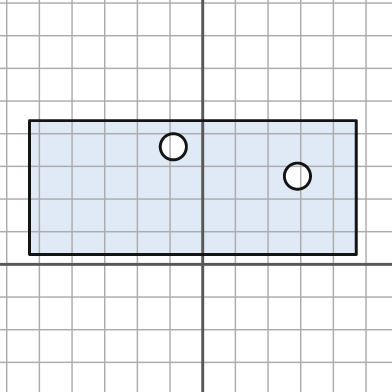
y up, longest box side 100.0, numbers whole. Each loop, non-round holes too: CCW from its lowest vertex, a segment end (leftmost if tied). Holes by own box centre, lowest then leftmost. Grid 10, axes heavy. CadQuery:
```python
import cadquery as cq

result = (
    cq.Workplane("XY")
    .moveTo(-53.0, 3.0)
    .lineTo(47.0, 3.0)
    .lineTo(47.0, 44.0)
    .lineTo(-53.0, 44.0)
    .close()
    .moveTo(29.0, 27.0)
    .circle(4.0)
    .moveTo(-9.0, 36.0)
    .circle(4.0)
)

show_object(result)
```